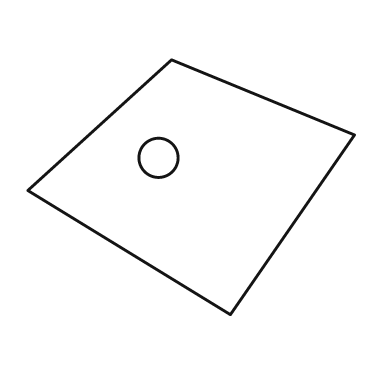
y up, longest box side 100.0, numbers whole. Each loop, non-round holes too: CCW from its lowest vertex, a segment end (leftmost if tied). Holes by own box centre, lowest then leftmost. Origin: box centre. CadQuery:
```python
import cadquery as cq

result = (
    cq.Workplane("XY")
    .moveTo(12.0, -39.0)
    .lineTo(50.0, 16.0)
    .lineTo(-6.0, 39.0)
    .lineTo(-50.0, -1.0)
    .close()
    .moveTo(-10.0, 9.0)
    .circle(6.0)
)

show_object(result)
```